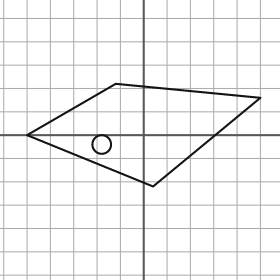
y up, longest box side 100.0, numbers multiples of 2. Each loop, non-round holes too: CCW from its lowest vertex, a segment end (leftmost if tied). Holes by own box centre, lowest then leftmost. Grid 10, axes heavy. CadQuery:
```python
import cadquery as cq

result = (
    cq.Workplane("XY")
    .moveTo(4.0, -22.0)
    .lineTo(50.0, 16.0)
    .lineTo(-12.0, 22.0)
    .lineTo(-50.0, 0.0)
    .close()
    .moveTo(-18.0, -4.0)
    .circle(4.0)
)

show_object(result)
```